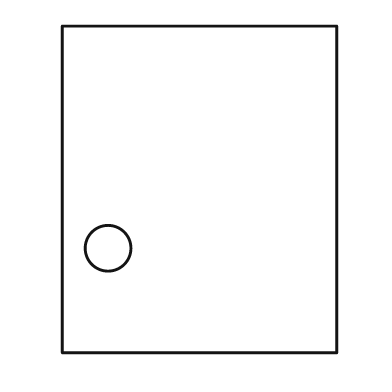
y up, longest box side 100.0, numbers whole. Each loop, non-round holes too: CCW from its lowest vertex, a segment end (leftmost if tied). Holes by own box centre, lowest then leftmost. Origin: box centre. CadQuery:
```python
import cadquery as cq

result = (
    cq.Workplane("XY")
    .moveTo(-42.0, -50.0)
    .lineTo(42.0, -50.0)
    .lineTo(42.0, 50.0)
    .lineTo(-42.0, 50.0)
    .close()
    .moveTo(-28.0, -18.0)
    .circle(7.0)
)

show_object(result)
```